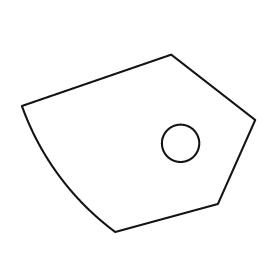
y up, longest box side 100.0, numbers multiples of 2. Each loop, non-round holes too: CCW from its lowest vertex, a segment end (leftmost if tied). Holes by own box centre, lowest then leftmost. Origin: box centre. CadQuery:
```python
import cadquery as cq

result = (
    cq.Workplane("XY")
    .moveTo(-10.0, -38.0)
    .lineTo(34.0, -26.0)
    .lineTo(50.0, 10.0)
    .lineTo(14.0, 38.0)
    .lineTo(-50.0, 16.0)
    .threePointArc((-34.0, -14.0), (-10.0, -38.0))
    .close()
    .moveTo(18.0, 0.0)
    .circle(8.0)
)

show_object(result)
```